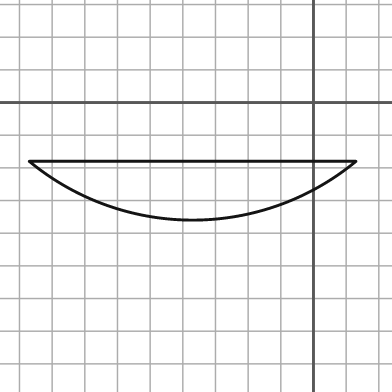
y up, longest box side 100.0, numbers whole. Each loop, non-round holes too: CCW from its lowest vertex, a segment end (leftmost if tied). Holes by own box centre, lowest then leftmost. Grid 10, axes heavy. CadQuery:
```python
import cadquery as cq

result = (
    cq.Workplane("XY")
    .moveTo(-87.0, -18.0)
    .threePointArc((-37.0, -36.0), (13.0, -18.0))
    .close()
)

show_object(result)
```